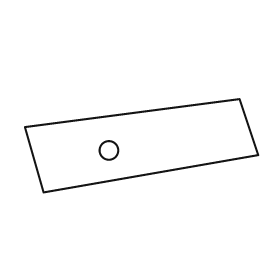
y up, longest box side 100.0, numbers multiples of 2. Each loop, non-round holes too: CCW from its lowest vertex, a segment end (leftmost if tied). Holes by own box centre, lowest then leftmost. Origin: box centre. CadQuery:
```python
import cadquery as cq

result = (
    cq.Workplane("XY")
    .moveTo(-42.0, -20.0)
    .lineTo(50.0, -4.0)
    .lineTo(42.0, 20.0)
    .lineTo(-50.0, 8.0)
    .close()
    .moveTo(-14.0, -2.0)
    .circle(4.0)
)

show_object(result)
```